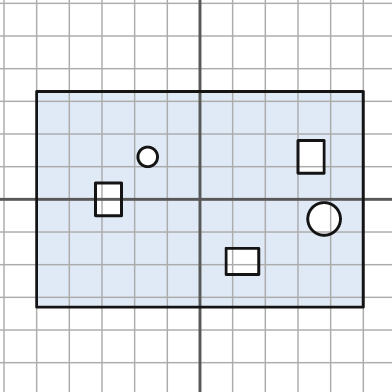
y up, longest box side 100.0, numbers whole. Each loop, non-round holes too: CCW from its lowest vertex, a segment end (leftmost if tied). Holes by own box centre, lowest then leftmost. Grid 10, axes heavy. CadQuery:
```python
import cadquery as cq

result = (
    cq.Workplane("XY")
    .moveTo(-50.0, -33.0)
    .lineTo(50.0, -33.0)
    .lineTo(50.0, 33.0)
    .lineTo(-50.0, 33.0)
    .close()
    .moveTo(8.0, -23.0)
    .lineTo(18.0, -23.0)
    .lineTo(18.0, -15.0)
    .lineTo(8.0, -15.0)
    .close()
    .moveTo(38.0, -6.0)
    .circle(5.0)
    .moveTo(-32.0, -5.0)
    .lineTo(-24.0, -5.0)
    .lineTo(-24.0, 5.0)
    .lineTo(-32.0, 5.0)
    .close()
    .moveTo(-16.0, 13.0)
    .circle(3.0)
    .moveTo(30.0, 8.0)
    .lineTo(38.0, 8.0)
    .lineTo(38.0, 18.0)
    .lineTo(30.0, 18.0)
    .close()
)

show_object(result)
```